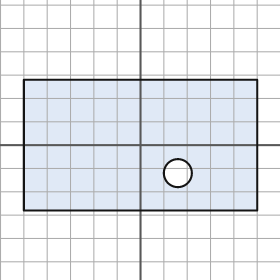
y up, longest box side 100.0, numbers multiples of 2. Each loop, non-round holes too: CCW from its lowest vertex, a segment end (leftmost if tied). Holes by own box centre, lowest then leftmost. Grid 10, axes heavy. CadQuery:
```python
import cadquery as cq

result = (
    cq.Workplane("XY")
    .moveTo(-50.0, -28.0)
    .lineTo(50.0, -28.0)
    .lineTo(50.0, 28.0)
    .lineTo(-50.0, 28.0)
    .close()
    .moveTo(16.0, -12.0)
    .circle(6.0)
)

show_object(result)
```